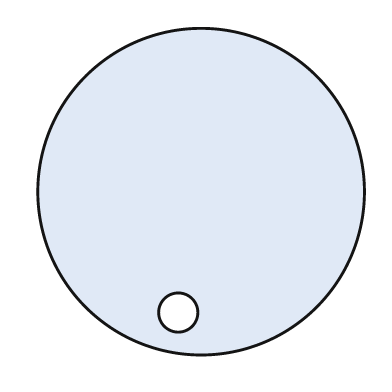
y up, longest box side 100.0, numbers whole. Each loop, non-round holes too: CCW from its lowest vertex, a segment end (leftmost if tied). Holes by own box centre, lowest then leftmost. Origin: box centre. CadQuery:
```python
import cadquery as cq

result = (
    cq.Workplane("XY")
    .moveTo(0.0, 0.0)
    .circle(50.0)
    .moveTo(-7.0, -37.0)
    .circle(6.0)
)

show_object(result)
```